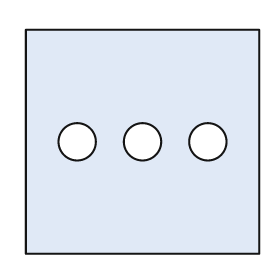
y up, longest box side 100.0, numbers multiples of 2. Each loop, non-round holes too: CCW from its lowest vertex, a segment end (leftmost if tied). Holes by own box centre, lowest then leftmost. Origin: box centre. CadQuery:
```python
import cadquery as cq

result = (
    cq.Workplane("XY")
    .moveTo(-50.0, -48.0)
    .lineTo(50.0, -48.0)
    .lineTo(50.0, 48.0)
    .lineTo(-50.0, 48.0)
    .close()
    .moveTo(-28.0, 0.0)
    .circle(8.0)
    .moveTo(0.0, 0.0)
    .circle(8.0)
    .moveTo(28.0, 0.0)
    .circle(8.0)
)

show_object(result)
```